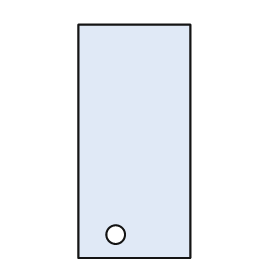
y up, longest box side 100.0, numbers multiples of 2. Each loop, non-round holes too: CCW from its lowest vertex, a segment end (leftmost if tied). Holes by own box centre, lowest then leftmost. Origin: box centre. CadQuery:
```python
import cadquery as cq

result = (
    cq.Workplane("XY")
    .moveTo(-24.0, -50.0)
    .lineTo(24.0, -50.0)
    .lineTo(24.0, 50.0)
    .lineTo(-24.0, 50.0)
    .close()
    .moveTo(-8.0, -40.0)
    .circle(4.0)
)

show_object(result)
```